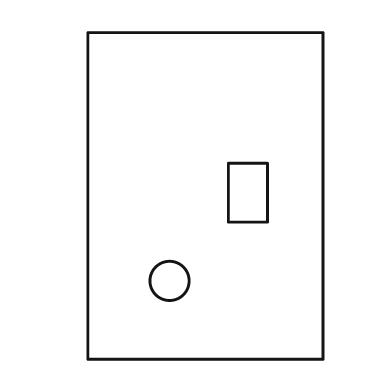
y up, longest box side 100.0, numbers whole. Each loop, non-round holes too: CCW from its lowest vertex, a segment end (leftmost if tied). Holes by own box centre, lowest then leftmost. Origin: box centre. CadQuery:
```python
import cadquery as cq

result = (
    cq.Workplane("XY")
    .moveTo(-36.0, -50.0)
    .lineTo(36.0, -50.0)
    .lineTo(36.0, 50.0)
    .lineTo(-36.0, 50.0)
    .close()
    .moveTo(-11.0, -26.0)
    .circle(6.0)
    .moveTo(7.0, -8.0)
    .lineTo(19.0, -8.0)
    .lineTo(19.0, 10.0)
    .lineTo(7.0, 10.0)
    .close()
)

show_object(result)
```